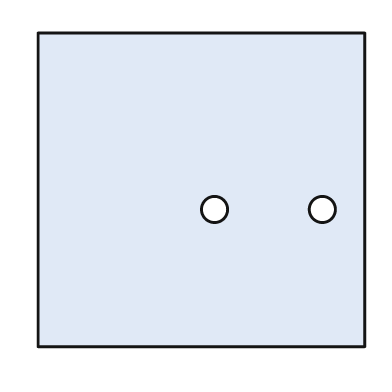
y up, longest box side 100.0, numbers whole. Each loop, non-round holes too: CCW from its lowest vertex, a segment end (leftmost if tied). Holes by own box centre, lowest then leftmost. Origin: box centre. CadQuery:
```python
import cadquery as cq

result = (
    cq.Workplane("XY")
    .moveTo(-50.0, -48.0)
    .lineTo(50.0, -48.0)
    .lineTo(50.0, 48.0)
    .lineTo(-50.0, 48.0)
    .close()
    .moveTo(4.0, -6.0)
    .circle(4.0)
    .moveTo(37.0, -6.0)
    .circle(4.0)
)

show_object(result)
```